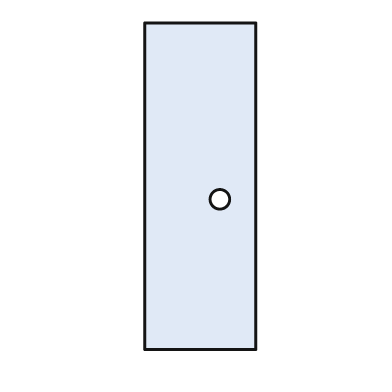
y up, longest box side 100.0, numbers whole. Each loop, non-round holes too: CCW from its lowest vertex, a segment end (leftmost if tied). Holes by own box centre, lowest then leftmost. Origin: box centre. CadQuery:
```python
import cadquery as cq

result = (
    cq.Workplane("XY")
    .moveTo(-17.0, -50.0)
    .lineTo(17.0, -50.0)
    .lineTo(17.0, 50.0)
    .lineTo(-17.0, 50.0)
    .close()
    .moveTo(6.0, -4.0)
    .circle(3.0)
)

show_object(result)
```